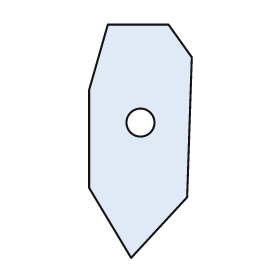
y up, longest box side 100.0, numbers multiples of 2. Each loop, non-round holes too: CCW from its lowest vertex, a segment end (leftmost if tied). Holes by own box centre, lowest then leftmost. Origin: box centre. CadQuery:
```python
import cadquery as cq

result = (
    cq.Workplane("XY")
    .moveTo(-4.0, -50.0)
    .lineTo(20.0, -24.0)
    .lineTo(22.0, 36.0)
    .lineTo(12.0, 50.0)
    .lineTo(-14.0, 50.0)
    .lineTo(-22.0, 22.0)
    .lineTo(-22.0, -20.0)
    .close()
    .moveTo(0.0, 8.0)
    .circle(6.0)
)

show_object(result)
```